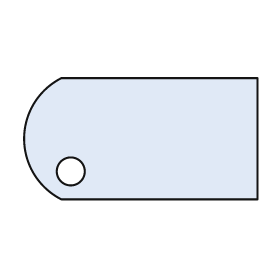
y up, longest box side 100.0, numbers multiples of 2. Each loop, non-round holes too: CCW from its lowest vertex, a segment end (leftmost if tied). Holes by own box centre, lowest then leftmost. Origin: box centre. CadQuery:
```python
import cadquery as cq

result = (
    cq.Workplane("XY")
    .moveTo(-34.0, -26.0)
    .lineTo(50.0, -26.0)
    .lineTo(50.0, 26.0)
    .lineTo(-34.0, 26.0)
    .threePointArc((-50.0, 0.0), (-34.0, -26.0))
    .close()
    .moveTo(-30.0, -14.0)
    .circle(6.0)
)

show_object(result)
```